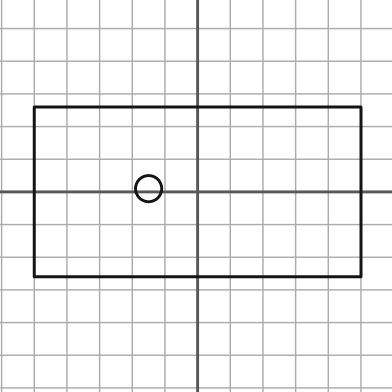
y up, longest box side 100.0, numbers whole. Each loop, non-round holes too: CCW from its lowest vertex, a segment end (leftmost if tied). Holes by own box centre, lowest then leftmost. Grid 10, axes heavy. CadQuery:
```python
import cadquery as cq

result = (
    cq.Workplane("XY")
    .moveTo(-50.0, -26.0)
    .lineTo(50.0, -26.0)
    .lineTo(50.0, 26.0)
    .lineTo(-50.0, 26.0)
    .close()
    .moveTo(-15.0, 1.0)
    .circle(4.0)
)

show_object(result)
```